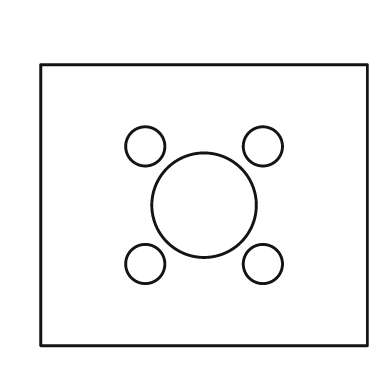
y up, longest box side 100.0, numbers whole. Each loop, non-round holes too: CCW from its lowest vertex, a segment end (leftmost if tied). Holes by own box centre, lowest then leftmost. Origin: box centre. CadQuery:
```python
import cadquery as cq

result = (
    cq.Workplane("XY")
    .moveTo(-50.0, -43.0)
    .lineTo(50.0, -43.0)
    .lineTo(50.0, 43.0)
    .lineTo(-50.0, 43.0)
    .close()
    .moveTo(-18.0, -18.0)
    .circle(6.0)
    .moveTo(18.0, -18.0)
    .circle(6.0)
    .moveTo(0.0, 0.0)
    .circle(16.0)
    .moveTo(-18.0, 18.0)
    .circle(6.0)
    .moveTo(18.0, 18.0)
    .circle(6.0)
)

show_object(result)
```